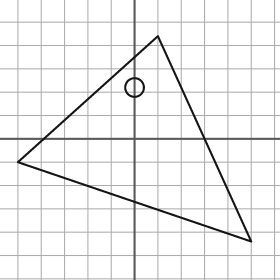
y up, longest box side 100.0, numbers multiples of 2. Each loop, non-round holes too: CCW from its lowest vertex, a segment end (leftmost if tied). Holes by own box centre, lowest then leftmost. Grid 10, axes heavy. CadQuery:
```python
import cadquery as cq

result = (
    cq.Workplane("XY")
    .moveTo(50.0, -44.0)
    .lineTo(10.0, 44.0)
    .lineTo(-50.0, -10.0)
    .close()
    .moveTo(0.0, 22.0)
    .circle(4.0)
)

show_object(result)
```